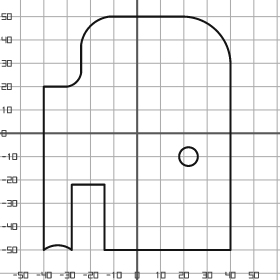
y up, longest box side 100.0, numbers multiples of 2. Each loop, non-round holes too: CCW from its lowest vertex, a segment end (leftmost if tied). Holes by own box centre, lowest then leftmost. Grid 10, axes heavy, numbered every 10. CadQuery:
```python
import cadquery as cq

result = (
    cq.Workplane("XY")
    .moveTo(-40.0, -50.0)
    .threePointArc((-34.0, -48.0), (-28.0, -50.0))
    .lineTo(-28.0, -22.0)
    .lineTo(-14.0, -22.0)
    .lineTo(-14.0, -50.0)
    .lineTo(40.0, -50.0)
    .lineTo(40.0, 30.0)
    .threePointArc((34.0, 44.0), (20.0, 50.0))
    .lineTo(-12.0, 50.0)
    .threePointArc((-20.0, 46.0), (-24.0, 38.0))
    .lineTo(-24.0, 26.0)
    .threePointArc((-26.0, 22.0), (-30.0, 20.0))
    .lineTo(-40.0, 20.0)
    .close()
    .moveTo(22.0, -10.0)
    .circle(4.0)
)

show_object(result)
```